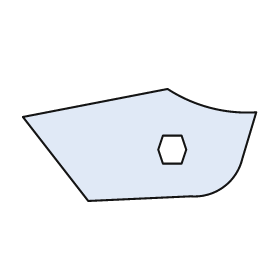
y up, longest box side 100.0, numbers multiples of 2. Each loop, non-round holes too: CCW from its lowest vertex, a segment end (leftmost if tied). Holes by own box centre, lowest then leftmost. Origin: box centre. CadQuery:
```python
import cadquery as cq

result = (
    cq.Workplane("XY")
    .moveTo(-22.0, -24.0)
    .lineTo(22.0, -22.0)
    .threePointArc((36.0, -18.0), (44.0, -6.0))
    .lineTo(50.0, 14.0)
    .threePointArc((30.0, 16.0), (12.0, 24.0))
    .lineTo(-50.0, 12.0)
    .close()
    .moveTo(10.0, -8.0)
    .lineTo(18.0, -8.0)
    .lineTo(20.0, -2.0)
    .lineTo(18.0, 4.0)
    .lineTo(10.0, 4.0)
    .lineTo(8.0, -2.0)
    .close()
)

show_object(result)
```